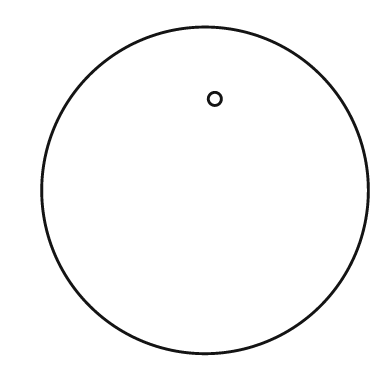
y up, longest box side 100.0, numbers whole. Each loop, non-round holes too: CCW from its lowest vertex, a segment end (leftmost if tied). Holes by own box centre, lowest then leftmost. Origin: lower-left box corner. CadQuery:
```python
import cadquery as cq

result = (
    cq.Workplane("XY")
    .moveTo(50.0, 50.0)
    .circle(50.0)
    .moveTo(53.0, 78.0)
    .circle(2.0)
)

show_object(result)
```